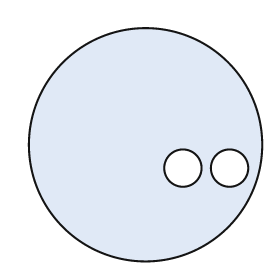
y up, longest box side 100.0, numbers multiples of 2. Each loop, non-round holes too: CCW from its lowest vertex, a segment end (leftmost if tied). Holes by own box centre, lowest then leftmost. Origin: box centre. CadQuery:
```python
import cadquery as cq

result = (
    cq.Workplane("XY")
    .moveTo(0.0, 0.0)
    .circle(50.0)
    .moveTo(16.0, -10.0)
    .circle(8.0)
    .moveTo(36.0, -10.0)
    .circle(8.0)
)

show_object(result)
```